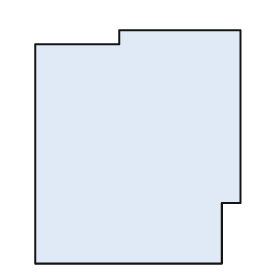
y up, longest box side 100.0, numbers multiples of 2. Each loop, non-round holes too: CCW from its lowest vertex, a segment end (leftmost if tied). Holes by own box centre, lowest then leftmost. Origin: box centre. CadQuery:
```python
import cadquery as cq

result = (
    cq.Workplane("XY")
    .moveTo(-44.0, -50.0)
    .lineTo(36.0, -50.0)
    .lineTo(36.0, -24.0)
    .lineTo(44.0, -24.0)
    .lineTo(44.0, 50.0)
    .lineTo(-8.0, 50.0)
    .lineTo(-8.0, 44.0)
    .lineTo(-44.0, 44.0)
    .close()
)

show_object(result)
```